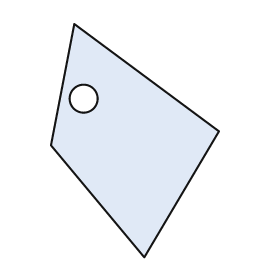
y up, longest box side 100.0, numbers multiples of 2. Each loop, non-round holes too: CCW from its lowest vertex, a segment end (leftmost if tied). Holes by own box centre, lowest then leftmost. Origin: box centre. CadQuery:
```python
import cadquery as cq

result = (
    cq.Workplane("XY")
    .moveTo(4.0, -50.0)
    .lineTo(36.0, 4.0)
    .lineTo(-26.0, 50.0)
    .lineTo(-36.0, -2.0)
    .close()
    .moveTo(-22.0, 18.0)
    .circle(6.0)
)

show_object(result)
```